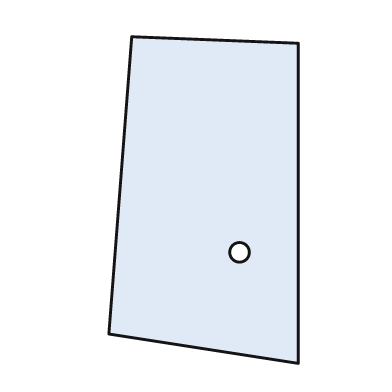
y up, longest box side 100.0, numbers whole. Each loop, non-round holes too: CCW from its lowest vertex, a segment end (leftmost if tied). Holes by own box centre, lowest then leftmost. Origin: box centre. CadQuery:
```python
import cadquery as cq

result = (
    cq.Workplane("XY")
    .moveTo(29.0, -50.0)
    .lineTo(29.0, 48.0)
    .lineTo(-22.0, 50.0)
    .lineTo(-29.0, -41.0)
    .close()
    .moveTo(11.0, -16.0)
    .circle(3.0)
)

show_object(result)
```